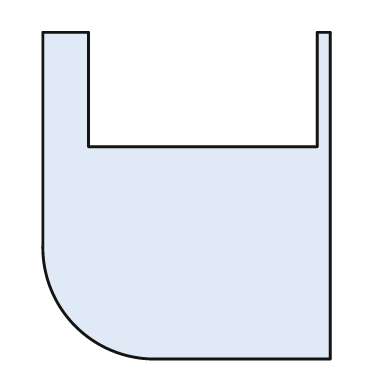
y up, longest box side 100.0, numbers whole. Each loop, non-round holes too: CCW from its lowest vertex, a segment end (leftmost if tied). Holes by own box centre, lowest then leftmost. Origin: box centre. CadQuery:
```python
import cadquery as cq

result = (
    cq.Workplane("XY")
    .moveTo(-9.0, -50.0)
    .lineTo(44.0, -50.0)
    .lineTo(44.0, 50.0)
    .lineTo(40.0, 50.0)
    .lineTo(40.0, 15.0)
    .lineTo(-30.0, 15.0)
    .lineTo(-30.0, 50.0)
    .lineTo(-44.0, 50.0)
    .lineTo(-44.0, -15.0)
    .threePointArc((-34.0, -40.0), (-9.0, -50.0))
    .close()
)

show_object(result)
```